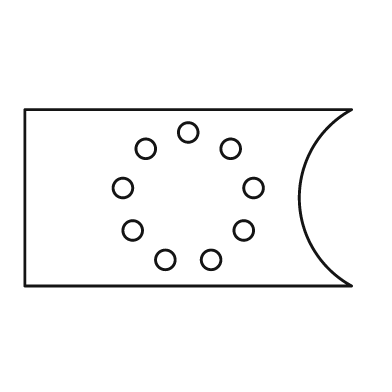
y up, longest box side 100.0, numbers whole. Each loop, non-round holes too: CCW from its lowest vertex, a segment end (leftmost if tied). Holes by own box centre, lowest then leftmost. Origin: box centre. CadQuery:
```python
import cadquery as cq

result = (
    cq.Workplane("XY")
    .moveTo(-50.0, -27.0)
    .lineTo(50.0, -27.0)
    .threePointArc((34.0, 0.0), (50.0, 27.0))
    .lineTo(-50.0, 27.0)
    .close()
    .moveTo(-7.0, -19.0)
    .circle(3.0)
    .moveTo(7.0, -19.0)
    .circle(3.0)
    .moveTo(-17.0, -10.0)
    .circle(3.0)
    .moveTo(17.0, -10.0)
    .circle(3.0)
    .moveTo(-20.0, 3.0)
    .circle(3.0)
    .moveTo(20.0, 3.0)
    .circle(3.0)
    .moveTo(-13.0, 15.0)
    .circle(3.0)
    .moveTo(13.0, 15.0)
    .circle(3.0)
    .moveTo(0.0, 20.0)
    .circle(3.0)
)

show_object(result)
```